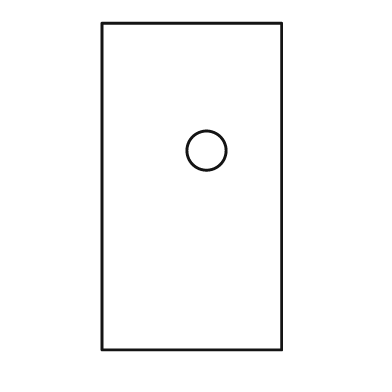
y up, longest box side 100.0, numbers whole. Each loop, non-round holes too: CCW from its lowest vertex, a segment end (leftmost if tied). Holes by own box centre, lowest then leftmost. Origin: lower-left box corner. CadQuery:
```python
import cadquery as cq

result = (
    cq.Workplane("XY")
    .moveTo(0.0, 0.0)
    .lineTo(55.0, 0.0)
    .lineTo(55.0, 100.0)
    .lineTo(0.0, 100.0)
    .close()
    .moveTo(32.0, 61.0)
    .circle(6.0)
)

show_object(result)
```